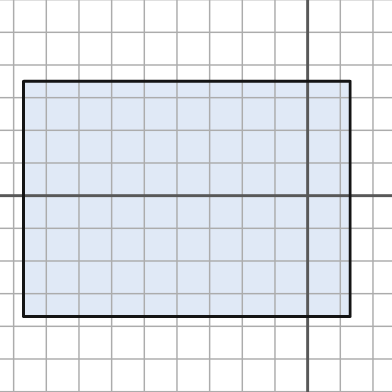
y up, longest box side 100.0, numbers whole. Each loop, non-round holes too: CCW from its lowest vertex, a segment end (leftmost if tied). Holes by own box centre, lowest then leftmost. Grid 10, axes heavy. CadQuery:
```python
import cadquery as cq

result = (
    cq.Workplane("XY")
    .moveTo(-87.0, -37.0)
    .lineTo(13.0, -37.0)
    .lineTo(13.0, 35.0)
    .lineTo(-87.0, 35.0)
    .close()
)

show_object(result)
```